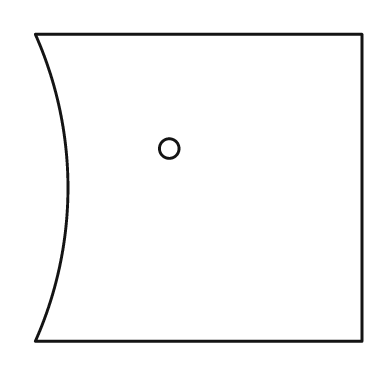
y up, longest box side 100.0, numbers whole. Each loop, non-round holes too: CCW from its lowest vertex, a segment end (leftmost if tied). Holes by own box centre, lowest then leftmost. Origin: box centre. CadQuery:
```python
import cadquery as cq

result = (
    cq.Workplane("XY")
    .moveTo(-50.0, -47.0)
    .lineTo(50.0, -47.0)
    .lineTo(50.0, 47.0)
    .lineTo(-50.0, 47.0)
    .threePointArc((-40.0, 0.0), (-50.0, -47.0))
    .close()
    .moveTo(-9.0, 12.0)
    .circle(3.0)
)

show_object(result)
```